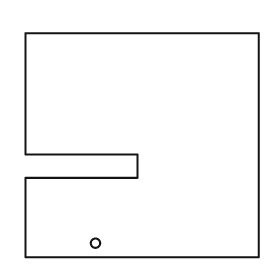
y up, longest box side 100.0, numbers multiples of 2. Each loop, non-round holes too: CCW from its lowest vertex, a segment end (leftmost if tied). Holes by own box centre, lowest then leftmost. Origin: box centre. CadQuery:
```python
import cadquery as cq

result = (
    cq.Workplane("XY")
    .moveTo(-50.0, -48.0)
    .lineTo(50.0, -48.0)
    .lineTo(50.0, 48.0)
    .lineTo(-50.0, 48.0)
    .lineTo(-50.0, -4.0)
    .lineTo(-2.0, -4.0)
    .lineTo(-2.0, -14.0)
    .lineTo(-50.0, -14.0)
    .close()
    .moveTo(-20.0, -42.0)
    .circle(2.0)
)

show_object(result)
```